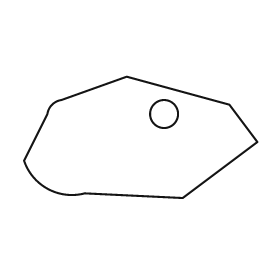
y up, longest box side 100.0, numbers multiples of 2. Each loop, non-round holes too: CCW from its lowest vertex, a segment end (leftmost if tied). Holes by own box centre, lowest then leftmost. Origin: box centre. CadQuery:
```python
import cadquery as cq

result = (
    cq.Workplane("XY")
    .moveTo(18.0, -26.0)
    .lineTo(50.0, -2.0)
    .lineTo(38.0, 14.0)
    .lineTo(-6.0, 26.0)
    .lineTo(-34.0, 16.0)
    .threePointArc((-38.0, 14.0), (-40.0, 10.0))
    .lineTo(-50.0, -10.0)
    .threePointArc((-40.0, -22.0), (-24.0, -24.0))
    .close()
    .moveTo(10.0, 10.0)
    .circle(6.0)
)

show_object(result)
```